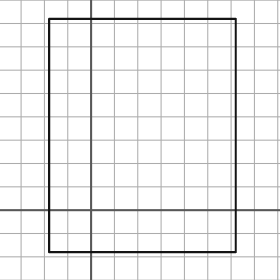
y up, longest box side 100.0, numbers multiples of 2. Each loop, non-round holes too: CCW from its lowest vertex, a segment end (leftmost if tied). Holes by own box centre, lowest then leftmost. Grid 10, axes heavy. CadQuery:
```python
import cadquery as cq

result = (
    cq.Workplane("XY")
    .moveTo(-18.0, -18.0)
    .lineTo(62.0, -18.0)
    .lineTo(62.0, 82.0)
    .lineTo(-18.0, 82.0)
    .close()
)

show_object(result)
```